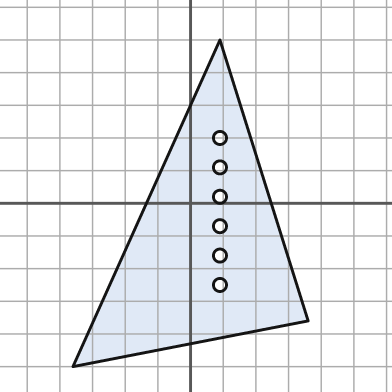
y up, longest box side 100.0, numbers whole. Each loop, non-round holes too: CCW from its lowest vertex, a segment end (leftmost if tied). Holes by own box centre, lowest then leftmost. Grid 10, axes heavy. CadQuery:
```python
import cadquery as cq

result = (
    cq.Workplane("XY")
    .moveTo(-36.0, -50.0)
    .lineTo(36.0, -36.0)
    .lineTo(9.0, 50.0)
    .close()
    .moveTo(9.0, -25.0)
    .circle(2.0)
    .moveTo(9.0, -16.0)
    .circle(2.0)
    .moveTo(9.0, -7.0)
    .circle(2.0)
    .moveTo(9.0, 2.0)
    .circle(2.0)
    .moveTo(9.0, 11.0)
    .circle(2.0)
    .moveTo(9.0, 20.0)
    .circle(2.0)
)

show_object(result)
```